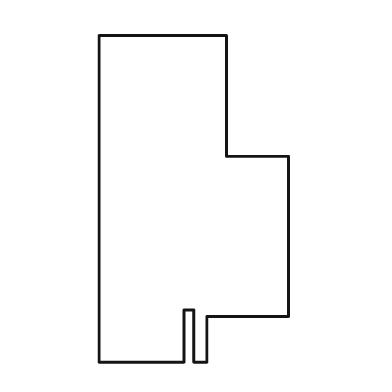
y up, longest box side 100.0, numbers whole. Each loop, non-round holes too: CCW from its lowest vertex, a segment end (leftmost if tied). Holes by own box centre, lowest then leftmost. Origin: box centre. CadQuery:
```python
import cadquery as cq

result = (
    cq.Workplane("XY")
    .moveTo(-29.0, -50.0)
    .lineTo(-3.0, -50.0)
    .lineTo(-3.0, -34.0)
    .lineTo(0.0, -34.0)
    .lineTo(0.0, -50.0)
    .lineTo(4.0, -50.0)
    .lineTo(4.0, -36.0)
    .lineTo(29.0, -36.0)
    .lineTo(29.0, 13.0)
    .lineTo(10.0, 13.0)
    .lineTo(10.0, 50.0)
    .lineTo(-29.0, 50.0)
    .close()
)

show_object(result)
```